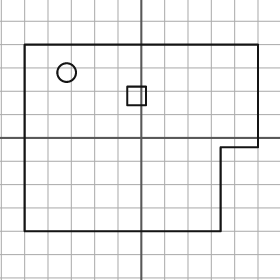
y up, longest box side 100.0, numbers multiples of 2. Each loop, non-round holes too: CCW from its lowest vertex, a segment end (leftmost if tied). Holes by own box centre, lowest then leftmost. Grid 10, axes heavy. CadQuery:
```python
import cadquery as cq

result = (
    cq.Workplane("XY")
    .moveTo(-50.0, -40.0)
    .lineTo(34.0, -40.0)
    .lineTo(34.0, -4.0)
    .lineTo(50.0, -4.0)
    .lineTo(50.0, 40.0)
    .lineTo(-50.0, 40.0)
    .close()
    .moveTo(-6.0, 14.0)
    .lineTo(2.0, 14.0)
    .lineTo(2.0, 22.0)
    .lineTo(-6.0, 22.0)
    .close()
    .moveTo(-32.0, 28.0)
    .circle(4.0)
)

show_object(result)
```